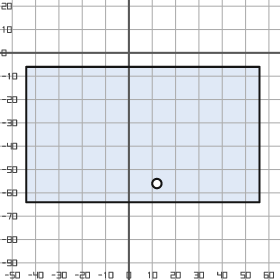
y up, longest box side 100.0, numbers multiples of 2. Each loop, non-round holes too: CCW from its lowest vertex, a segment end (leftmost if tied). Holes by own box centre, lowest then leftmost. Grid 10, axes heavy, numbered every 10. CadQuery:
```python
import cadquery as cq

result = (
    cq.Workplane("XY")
    .moveTo(-44.0, -64.0)
    .lineTo(56.0, -64.0)
    .lineTo(56.0, -6.0)
    .lineTo(-44.0, -6.0)
    .close()
    .moveTo(12.0, -56.0)
    .circle(2.0)
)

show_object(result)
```